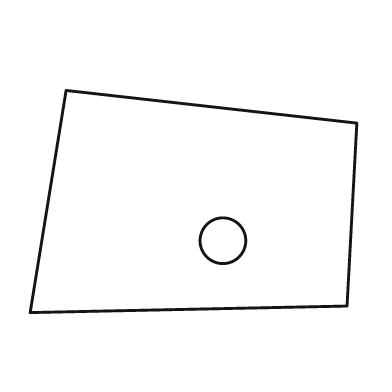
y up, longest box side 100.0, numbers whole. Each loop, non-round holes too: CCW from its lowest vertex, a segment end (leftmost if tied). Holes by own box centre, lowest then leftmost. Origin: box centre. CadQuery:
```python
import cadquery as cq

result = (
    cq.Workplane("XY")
    .moveTo(-50.0, -34.0)
    .lineTo(47.0, -32.0)
    .lineTo(50.0, 24.0)
    .lineTo(-39.0, 34.0)
    .close()
    .moveTo(9.0, -12.0)
    .circle(7.0)
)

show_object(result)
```